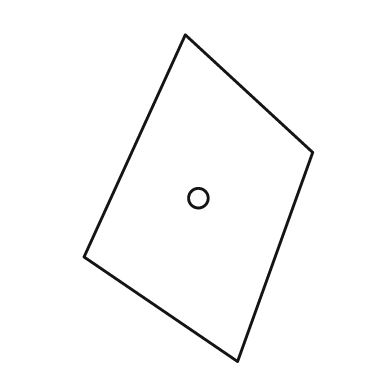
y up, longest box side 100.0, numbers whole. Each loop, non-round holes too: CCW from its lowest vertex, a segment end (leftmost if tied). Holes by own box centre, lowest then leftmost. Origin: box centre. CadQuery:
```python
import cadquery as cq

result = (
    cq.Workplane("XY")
    .moveTo(12.0, -50.0)
    .lineTo(35.0, 14.0)
    .lineTo(-4.0, 50.0)
    .lineTo(-35.0, -18.0)
    .close()
    .moveTo(0.0, 0.0)
    .circle(3.0)
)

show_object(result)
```